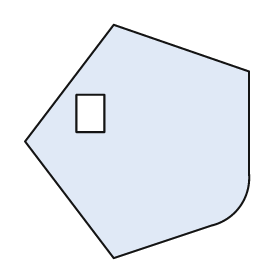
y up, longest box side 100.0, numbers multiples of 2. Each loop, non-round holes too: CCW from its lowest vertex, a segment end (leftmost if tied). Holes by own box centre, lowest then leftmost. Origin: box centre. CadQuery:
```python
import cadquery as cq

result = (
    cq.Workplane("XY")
    .moveTo(-10.0, -50.0)
    .lineTo(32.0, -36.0)
    .threePointArc((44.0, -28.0), (48.0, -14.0))
    .lineTo(48.0, 30.0)
    .lineTo(-10.0, 50.0)
    .lineTo(-48.0, 0.0)
    .close()
    .moveTo(-26.0, 4.0)
    .lineTo(-14.0, 4.0)
    .lineTo(-14.0, 20.0)
    .lineTo(-26.0, 20.0)
    .close()
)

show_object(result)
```